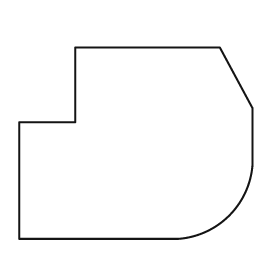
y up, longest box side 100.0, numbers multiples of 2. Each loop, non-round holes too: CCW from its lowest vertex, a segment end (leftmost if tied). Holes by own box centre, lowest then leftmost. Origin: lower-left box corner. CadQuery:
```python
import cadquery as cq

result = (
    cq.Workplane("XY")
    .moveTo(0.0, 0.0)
    .lineTo(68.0, 0.0)
    .threePointArc((90.0, 10.0), (100.0, 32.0))
    .lineTo(100.0, 56.0)
    .lineTo(86.0, 82.0)
    .lineTo(24.0, 82.0)
    .lineTo(24.0, 50.0)
    .lineTo(0.0, 50.0)
    .close()
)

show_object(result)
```